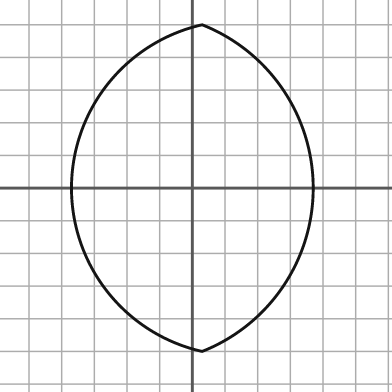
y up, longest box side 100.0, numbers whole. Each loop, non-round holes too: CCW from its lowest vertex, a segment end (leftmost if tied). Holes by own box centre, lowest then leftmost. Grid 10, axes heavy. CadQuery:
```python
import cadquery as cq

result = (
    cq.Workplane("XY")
    .moveTo(3.0, -50.0)
    .threePointArc((37.0, 0.0), (3.0, 50.0))
    .threePointArc((-37.0, 0.0), (3.0, -50.0))
    .close()
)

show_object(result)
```